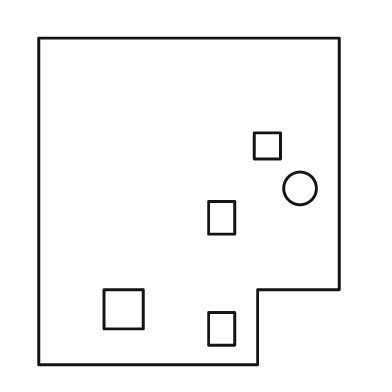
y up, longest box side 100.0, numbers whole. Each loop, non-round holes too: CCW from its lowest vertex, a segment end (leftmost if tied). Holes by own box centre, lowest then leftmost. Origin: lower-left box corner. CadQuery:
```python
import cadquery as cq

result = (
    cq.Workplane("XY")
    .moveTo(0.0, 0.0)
    .lineTo(67.0, 0.0)
    .lineTo(67.0, 23.0)
    .lineTo(92.0, 23.0)
    .lineTo(92.0, 100.0)
    .lineTo(0.0, 100.0)
    .close()
    .moveTo(52.0, 6.0)
    .lineTo(60.0, 6.0)
    .lineTo(60.0, 16.0)
    .lineTo(52.0, 16.0)
    .close()
    .moveTo(20.0, 11.0)
    .lineTo(32.0, 11.0)
    .lineTo(32.0, 23.0)
    .lineTo(20.0, 23.0)
    .close()
    .moveTo(52.0, 40.0)
    .lineTo(60.0, 40.0)
    .lineTo(60.0, 50.0)
    .lineTo(52.0, 50.0)
    .close()
    .moveTo(80.0, 54.0)
    .circle(5.0)
    .moveTo(66.0, 63.0)
    .lineTo(74.0, 63.0)
    .lineTo(74.0, 71.0)
    .lineTo(66.0, 71.0)
    .close()
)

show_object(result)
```